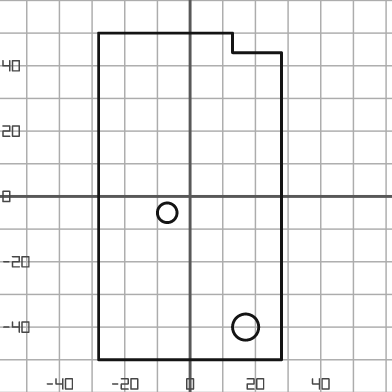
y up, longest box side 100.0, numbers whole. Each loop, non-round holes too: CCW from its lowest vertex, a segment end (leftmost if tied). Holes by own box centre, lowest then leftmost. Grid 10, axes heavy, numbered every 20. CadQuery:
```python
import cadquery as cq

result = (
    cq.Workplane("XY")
    .moveTo(-28.0, -50.0)
    .lineTo(28.0, -50.0)
    .lineTo(28.0, 44.0)
    .lineTo(13.0, 44.0)
    .lineTo(13.0, 50.0)
    .lineTo(-28.0, 50.0)
    .close()
    .moveTo(17.0, -40.0)
    .circle(4.0)
    .moveTo(-7.0, -5.0)
    .circle(3.0)
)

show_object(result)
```